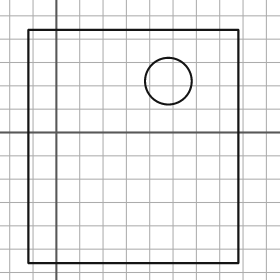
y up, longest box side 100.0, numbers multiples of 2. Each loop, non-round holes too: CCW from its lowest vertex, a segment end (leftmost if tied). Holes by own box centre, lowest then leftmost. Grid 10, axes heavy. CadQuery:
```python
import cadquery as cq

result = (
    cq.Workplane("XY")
    .moveTo(-12.0, -56.0)
    .lineTo(78.0, -56.0)
    .lineTo(78.0, 44.0)
    .lineTo(-12.0, 44.0)
    .close()
    .moveTo(48.0, 22.0)
    .circle(10.0)
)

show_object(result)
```